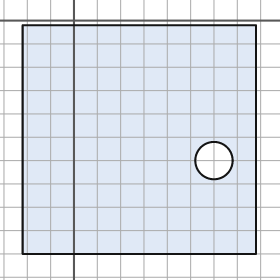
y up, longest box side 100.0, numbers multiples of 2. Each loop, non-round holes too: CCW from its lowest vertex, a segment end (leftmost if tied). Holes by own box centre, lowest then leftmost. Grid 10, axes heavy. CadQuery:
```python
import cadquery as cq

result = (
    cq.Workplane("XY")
    .moveTo(-22.0, -100.0)
    .lineTo(78.0, -100.0)
    .lineTo(78.0, -2.0)
    .lineTo(-22.0, -2.0)
    .close()
    .moveTo(60.0, -60.0)
    .circle(8.0)
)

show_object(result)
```